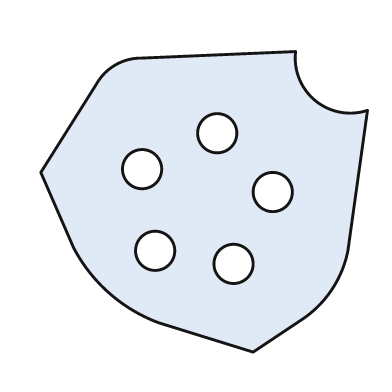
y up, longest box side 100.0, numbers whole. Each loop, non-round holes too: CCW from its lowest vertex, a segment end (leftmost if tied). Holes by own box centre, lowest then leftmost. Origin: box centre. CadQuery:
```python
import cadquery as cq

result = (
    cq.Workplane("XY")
    .moveTo(15.0, -46.0)
    .lineTo(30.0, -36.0)
    .threePointArc((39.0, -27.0), (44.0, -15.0))
    .lineTo(50.0, 28.0)
    .threePointArc((34.0, 31.0), (28.0, 46.0))
    .lineTo(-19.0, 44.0)
    .threePointArc((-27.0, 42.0), (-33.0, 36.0))
    .lineTo(-50.0, 9.0)
    .lineTo(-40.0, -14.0)
    .threePointArc((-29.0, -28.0), (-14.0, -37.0))
    .close()
    .moveTo(9.0, -19.0)
    .circle(6.0)
    .moveTo(-15.0, -15.0)
    .circle(6.0)
    .moveTo(21.0, 3.0)
    .circle(6.0)
    .moveTo(-19.0, 10.0)
    .circle(6.0)
    .moveTo(4.0, 21.0)
    .circle(6.0)
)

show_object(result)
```